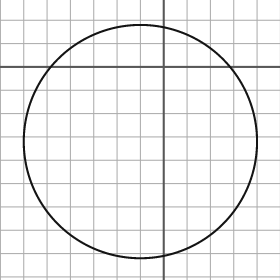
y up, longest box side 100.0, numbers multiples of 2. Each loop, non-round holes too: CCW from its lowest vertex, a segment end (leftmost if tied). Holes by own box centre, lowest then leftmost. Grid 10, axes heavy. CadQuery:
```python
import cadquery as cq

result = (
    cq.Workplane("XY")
    .moveTo(-10.0, -32.0)
    .circle(50.0)
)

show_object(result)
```